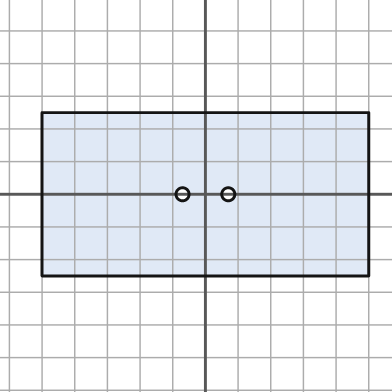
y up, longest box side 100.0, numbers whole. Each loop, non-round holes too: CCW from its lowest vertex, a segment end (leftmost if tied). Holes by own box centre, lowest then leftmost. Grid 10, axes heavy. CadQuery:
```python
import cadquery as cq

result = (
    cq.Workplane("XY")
    .moveTo(-50.0, -25.0)
    .lineTo(50.0, -25.0)
    .lineTo(50.0, 25.0)
    .lineTo(-50.0, 25.0)
    .close()
    .moveTo(-7.0, 0.0)
    .circle(2.0)
    .moveTo(7.0, 0.0)
    .circle(2.0)
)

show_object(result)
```